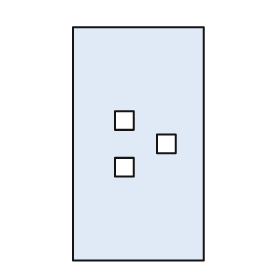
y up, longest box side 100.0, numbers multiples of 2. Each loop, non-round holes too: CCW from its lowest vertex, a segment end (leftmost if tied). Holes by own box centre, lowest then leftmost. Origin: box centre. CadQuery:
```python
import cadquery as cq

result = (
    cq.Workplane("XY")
    .moveTo(-28.0, -50.0)
    .lineTo(28.0, -50.0)
    .lineTo(28.0, 50.0)
    .lineTo(-28.0, 50.0)
    .close()
    .moveTo(-10.0, -14.0)
    .lineTo(-2.0, -14.0)
    .lineTo(-2.0, -6.0)
    .lineTo(-10.0, -6.0)
    .close()
    .moveTo(8.0, -4.0)
    .lineTo(16.0, -4.0)
    .lineTo(16.0, 4.0)
    .lineTo(8.0, 4.0)
    .close()
    .moveTo(-10.0, 6.0)
    .lineTo(-2.0, 6.0)
    .lineTo(-2.0, 14.0)
    .lineTo(-10.0, 14.0)
    .close()
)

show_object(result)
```